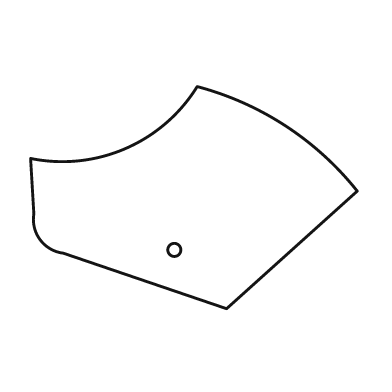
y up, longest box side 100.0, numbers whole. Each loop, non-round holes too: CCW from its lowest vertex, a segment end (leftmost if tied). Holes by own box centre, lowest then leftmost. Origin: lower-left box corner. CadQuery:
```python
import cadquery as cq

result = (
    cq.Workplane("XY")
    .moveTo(60.0, 0.0)
    .lineTo(100.0, 36.0)
    .threePointArc((78.0, 56.0), (51.0, 68.0))
    .threePointArc((29.0, 49.0), (0.0, 46.0))
    .lineTo(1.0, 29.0)
    .threePointArc((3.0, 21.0), (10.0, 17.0))
    .close()
    .moveTo(44.0, 18.0)
    .circle(2.0)
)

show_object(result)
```